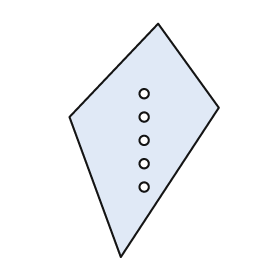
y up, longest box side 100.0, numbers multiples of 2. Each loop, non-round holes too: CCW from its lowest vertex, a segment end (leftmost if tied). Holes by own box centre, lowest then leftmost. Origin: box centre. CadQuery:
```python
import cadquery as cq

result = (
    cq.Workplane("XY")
    .moveTo(-10.0, -50.0)
    .lineTo(32.0, 14.0)
    .lineTo(6.0, 50.0)
    .lineTo(-32.0, 10.0)
    .close()
    .moveTo(0.0, -20.0)
    .circle(2.0)
    .moveTo(0.0, -10.0)
    .circle(2.0)
    .moveTo(0.0, 0.0)
    .circle(2.0)
    .moveTo(0.0, 10.0)
    .circle(2.0)
    .moveTo(0.0, 20.0)
    .circle(2.0)
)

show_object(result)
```